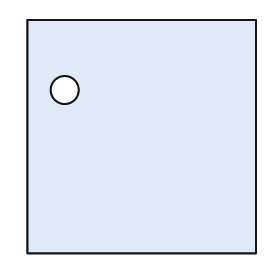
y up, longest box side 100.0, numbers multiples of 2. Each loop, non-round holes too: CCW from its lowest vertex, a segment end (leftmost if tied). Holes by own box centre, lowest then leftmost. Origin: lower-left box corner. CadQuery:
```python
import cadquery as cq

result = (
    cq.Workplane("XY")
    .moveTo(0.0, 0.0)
    .lineTo(98.0, 0.0)
    .lineTo(98.0, 100.0)
    .lineTo(0.0, 100.0)
    .close()
    .moveTo(16.0, 70.0)
    .circle(6.0)
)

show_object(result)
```